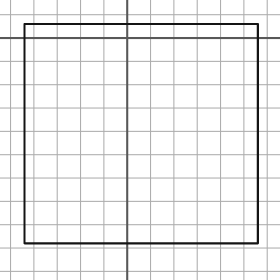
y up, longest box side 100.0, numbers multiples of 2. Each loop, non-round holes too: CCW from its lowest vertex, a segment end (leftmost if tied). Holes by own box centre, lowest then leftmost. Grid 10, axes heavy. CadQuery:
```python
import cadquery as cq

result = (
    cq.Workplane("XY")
    .moveTo(-44.0, -88.0)
    .lineTo(56.0, -88.0)
    .lineTo(56.0, 6.0)
    .lineTo(-44.0, 6.0)
    .close()
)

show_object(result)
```